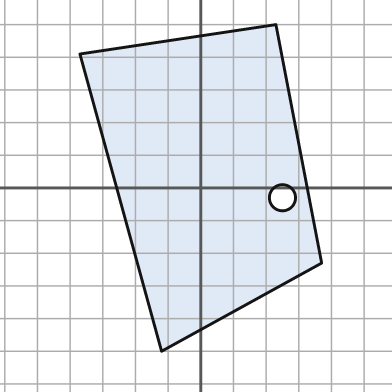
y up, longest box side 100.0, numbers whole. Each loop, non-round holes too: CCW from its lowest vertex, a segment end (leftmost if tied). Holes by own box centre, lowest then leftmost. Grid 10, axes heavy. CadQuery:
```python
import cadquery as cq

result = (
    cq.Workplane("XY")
    .moveTo(-12.0, -50.0)
    .lineTo(37.0, -23.0)
    .lineTo(23.0, 50.0)
    .lineTo(-37.0, 41.0)
    .close()
    .moveTo(25.0, -3.0)
    .circle(4.0)
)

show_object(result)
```